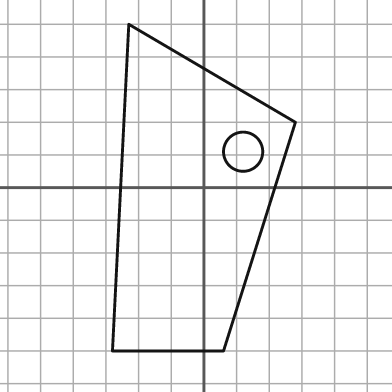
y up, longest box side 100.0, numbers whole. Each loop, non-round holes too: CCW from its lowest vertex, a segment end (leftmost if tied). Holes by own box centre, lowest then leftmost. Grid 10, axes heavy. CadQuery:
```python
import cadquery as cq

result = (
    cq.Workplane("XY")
    .moveTo(-28.0, -50.0)
    .lineTo(6.0, -50.0)
    .lineTo(28.0, 20.0)
    .lineTo(-23.0, 50.0)
    .close()
    .moveTo(12.0, 11.0)
    .circle(6.0)
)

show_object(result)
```